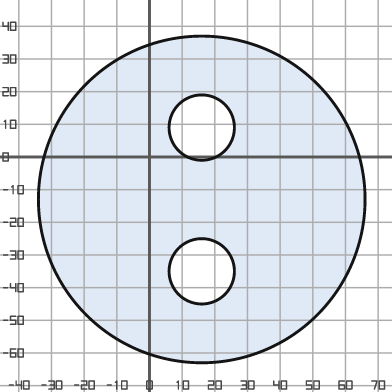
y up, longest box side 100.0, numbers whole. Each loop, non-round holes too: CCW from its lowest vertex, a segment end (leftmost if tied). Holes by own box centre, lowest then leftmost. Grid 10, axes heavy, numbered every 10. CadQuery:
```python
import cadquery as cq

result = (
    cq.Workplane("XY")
    .moveTo(16.0, -13.0)
    .circle(50.0)
    .moveTo(16.0, -35.0)
    .circle(10.0)
    .moveTo(16.0, 9.0)
    .circle(10.0)
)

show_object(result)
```